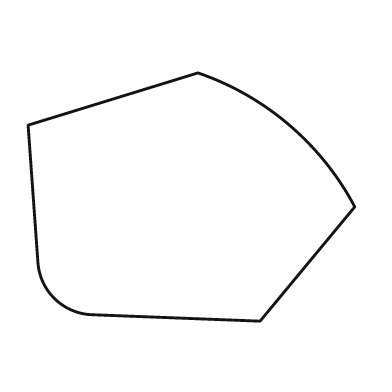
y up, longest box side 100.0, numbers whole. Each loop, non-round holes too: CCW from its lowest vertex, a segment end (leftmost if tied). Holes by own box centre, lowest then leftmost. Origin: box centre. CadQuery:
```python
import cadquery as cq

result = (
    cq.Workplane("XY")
    .moveTo(21.0, -38.0)
    .lineTo(50.0, -3.0)
    .threePointArc((30.0, 22.0), (2.0, 38.0))
    .lineTo(-50.0, 22.0)
    .lineTo(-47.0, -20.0)
    .threePointArc((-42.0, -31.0), (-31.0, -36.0))
    .close()
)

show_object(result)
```